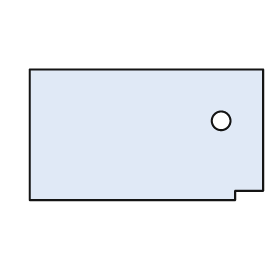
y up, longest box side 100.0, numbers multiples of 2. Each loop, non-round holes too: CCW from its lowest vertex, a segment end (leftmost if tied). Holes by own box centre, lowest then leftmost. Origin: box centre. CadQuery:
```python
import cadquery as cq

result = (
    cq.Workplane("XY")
    .moveTo(-50.0, -28.0)
    .lineTo(38.0, -28.0)
    .lineTo(38.0, -24.0)
    .lineTo(50.0, -24.0)
    .lineTo(50.0, 28.0)
    .lineTo(-50.0, 28.0)
    .close()
    .moveTo(32.0, 6.0)
    .circle(4.0)
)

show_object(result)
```